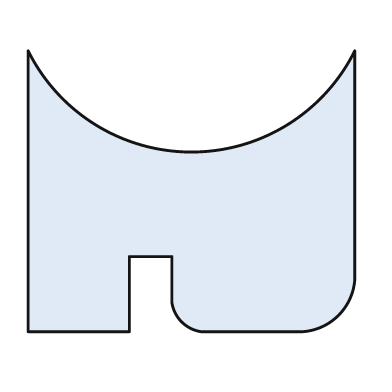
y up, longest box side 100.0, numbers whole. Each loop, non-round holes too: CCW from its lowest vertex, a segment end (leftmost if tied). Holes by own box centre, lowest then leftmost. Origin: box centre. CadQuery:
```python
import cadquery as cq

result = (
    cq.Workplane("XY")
    .moveTo(-50.0, -43.0)
    .lineTo(-19.0, -43.0)
    .lineTo(-19.0, -20.0)
    .lineTo(-6.0, -20.0)
    .lineTo(-6.0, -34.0)
    .threePointArc((-3.0, -40.0), (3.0, -43.0))
    .lineTo(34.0, -43.0)
    .threePointArc((45.0, -38.0), (50.0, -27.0))
    .lineTo(50.0, 43.0)
    .threePointArc((0.0, 12.0), (-50.0, 43.0))
    .close()
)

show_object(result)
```